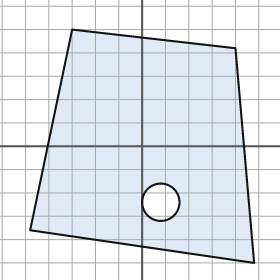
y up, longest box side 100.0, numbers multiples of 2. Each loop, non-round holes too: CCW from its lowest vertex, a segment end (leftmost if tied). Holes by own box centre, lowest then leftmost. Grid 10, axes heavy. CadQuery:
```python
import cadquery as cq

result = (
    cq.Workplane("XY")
    .moveTo(48.0, -50.0)
    .lineTo(40.0, 42.0)
    .lineTo(-30.0, 50.0)
    .lineTo(-48.0, -36.0)
    .close()
    .moveTo(8.0, -24.0)
    .circle(8.0)
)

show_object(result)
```